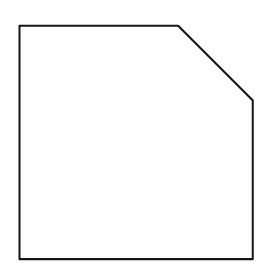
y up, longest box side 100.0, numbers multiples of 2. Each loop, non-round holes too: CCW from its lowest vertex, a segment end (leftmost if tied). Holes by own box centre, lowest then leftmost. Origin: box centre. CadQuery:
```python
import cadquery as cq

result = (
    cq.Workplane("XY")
    .moveTo(-50.0, -50.0)
    .lineTo(50.0, -50.0)
    .lineTo(50.0, 18.0)
    .lineTo(18.0, 50.0)
    .lineTo(-50.0, 50.0)
    .close()
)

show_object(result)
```